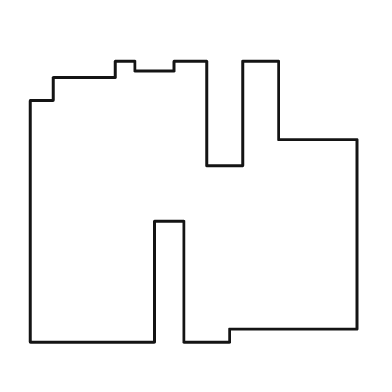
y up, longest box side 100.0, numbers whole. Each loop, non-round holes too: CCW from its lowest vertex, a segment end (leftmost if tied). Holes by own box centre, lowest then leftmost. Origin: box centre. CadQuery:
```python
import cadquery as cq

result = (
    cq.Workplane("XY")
    .moveTo(-50.0, -43.0)
    .lineTo(-12.0, -43.0)
    .lineTo(-12.0, -6.0)
    .lineTo(-3.0, -6.0)
    .lineTo(-3.0, -43.0)
    .lineTo(11.0, -43.0)
    .lineTo(11.0, -39.0)
    .lineTo(50.0, -39.0)
    .lineTo(50.0, 19.0)
    .lineTo(26.0, 19.0)
    .lineTo(26.0, 43.0)
    .lineTo(15.0, 43.0)
    .lineTo(15.0, 11.0)
    .lineTo(4.0, 11.0)
    .lineTo(4.0, 43.0)
    .lineTo(-6.0, 43.0)
    .lineTo(-6.0, 40.0)
    .lineTo(-18.0, 40.0)
    .lineTo(-18.0, 43.0)
    .lineTo(-24.0, 43.0)
    .lineTo(-24.0, 38.0)
    .lineTo(-43.0, 38.0)
    .lineTo(-43.0, 31.0)
    .lineTo(-50.0, 31.0)
    .close()
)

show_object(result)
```